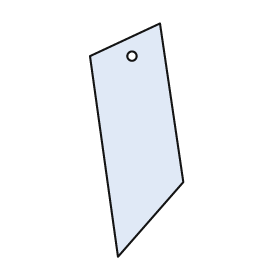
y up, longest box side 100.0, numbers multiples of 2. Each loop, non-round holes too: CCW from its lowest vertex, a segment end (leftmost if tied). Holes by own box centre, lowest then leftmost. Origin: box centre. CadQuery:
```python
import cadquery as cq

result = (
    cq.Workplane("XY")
    .moveTo(-8.0, -50.0)
    .lineTo(20.0, -18.0)
    .lineTo(10.0, 50.0)
    .lineTo(-20.0, 36.0)
    .close()
    .moveTo(-2.0, 36.0)
    .circle(2.0)
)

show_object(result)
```